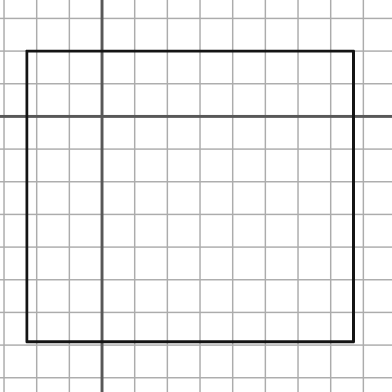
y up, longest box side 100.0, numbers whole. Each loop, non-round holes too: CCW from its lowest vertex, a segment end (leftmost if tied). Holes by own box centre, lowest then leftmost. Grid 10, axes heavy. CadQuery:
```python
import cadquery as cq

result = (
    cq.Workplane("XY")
    .moveTo(-23.0, -69.0)
    .lineTo(77.0, -69.0)
    .lineTo(77.0, 20.0)
    .lineTo(-23.0, 20.0)
    .close()
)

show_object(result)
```